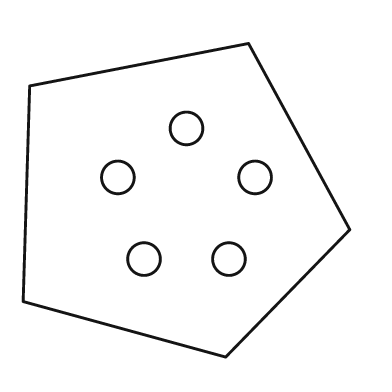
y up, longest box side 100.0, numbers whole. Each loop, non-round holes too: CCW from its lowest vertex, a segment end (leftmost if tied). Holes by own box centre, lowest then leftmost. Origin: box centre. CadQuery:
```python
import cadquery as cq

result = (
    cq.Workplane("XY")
    .moveTo(12.0, -48.0)
    .lineTo(50.0, -9.0)
    .lineTo(19.0, 48.0)
    .lineTo(-48.0, 35.0)
    .lineTo(-50.0, -31.0)
    .close()
    .moveTo(-13.0, -18.0)
    .circle(5.0)
    .moveTo(13.0, -18.0)
    .circle(5.0)
    .moveTo(-21.0, 7.0)
    .circle(5.0)
    .moveTo(21.0, 7.0)
    .circle(5.0)
    .moveTo(0.0, 22.0)
    .circle(5.0)
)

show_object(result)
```